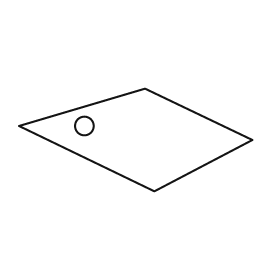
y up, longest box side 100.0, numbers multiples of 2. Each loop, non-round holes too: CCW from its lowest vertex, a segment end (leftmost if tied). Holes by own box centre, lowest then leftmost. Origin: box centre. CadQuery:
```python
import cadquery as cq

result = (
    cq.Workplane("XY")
    .moveTo(8.0, -22.0)
    .lineTo(50.0, 0.0)
    .lineTo(4.0, 22.0)
    .lineTo(-50.0, 6.0)
    .close()
    .moveTo(-22.0, 6.0)
    .circle(4.0)
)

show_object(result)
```